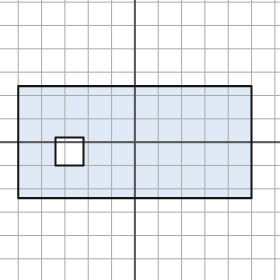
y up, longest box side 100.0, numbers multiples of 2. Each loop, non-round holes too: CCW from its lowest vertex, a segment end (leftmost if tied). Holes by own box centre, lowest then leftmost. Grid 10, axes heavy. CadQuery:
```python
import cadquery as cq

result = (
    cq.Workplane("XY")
    .moveTo(-50.0, -24.0)
    .lineTo(50.0, -24.0)
    .lineTo(50.0, 24.0)
    .lineTo(-50.0, 24.0)
    .close()
    .moveTo(-34.0, -10.0)
    .lineTo(-22.0, -10.0)
    .lineTo(-22.0, 2.0)
    .lineTo(-34.0, 2.0)
    .close()
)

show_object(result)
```